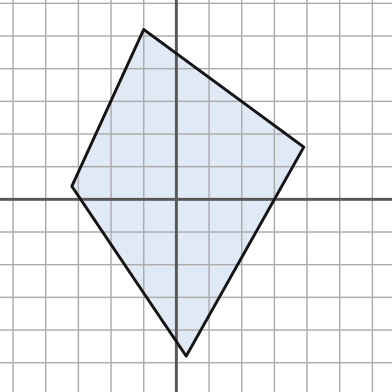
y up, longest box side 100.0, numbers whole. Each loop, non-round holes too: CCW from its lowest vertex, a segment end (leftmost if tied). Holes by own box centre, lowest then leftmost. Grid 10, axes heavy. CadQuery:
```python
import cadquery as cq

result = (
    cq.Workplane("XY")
    .moveTo(3.0, -48.0)
    .lineTo(39.0, 16.0)
    .lineTo(-10.0, 52.0)
    .lineTo(-32.0, 4.0)
    .close()
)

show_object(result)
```